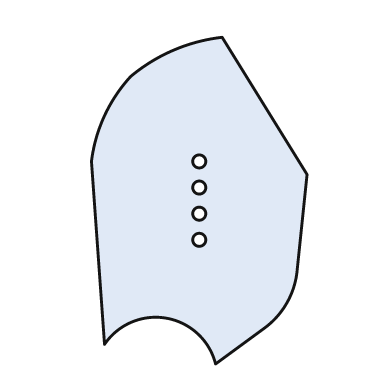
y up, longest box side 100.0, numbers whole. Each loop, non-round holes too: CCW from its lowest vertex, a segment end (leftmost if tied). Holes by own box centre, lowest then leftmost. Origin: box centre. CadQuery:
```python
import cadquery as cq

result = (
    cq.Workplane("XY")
    .moveTo(5.0, -50.0)
    .lineTo(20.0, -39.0)
    .threePointArc((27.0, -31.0), (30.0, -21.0))
    .lineTo(33.0, 8.0)
    .lineTo(7.0, 50.0)
    .threePointArc((-8.0, 46.0), (-21.0, 38.0))
    .threePointArc((-29.0, 26.0), (-33.0, 12.0))
    .lineTo(-29.0, -44.0)
    .threePointArc((-10.0, -36.0), (5.0, -50.0))
    .close()
    .moveTo(0.0, -12.0)
    .circle(2.0)
    .moveTo(0.0, -4.0)
    .circle(2.0)
    .moveTo(0.0, 4.0)
    .circle(2.0)
    .moveTo(0.0, 12.0)
    .circle(2.0)
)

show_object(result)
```